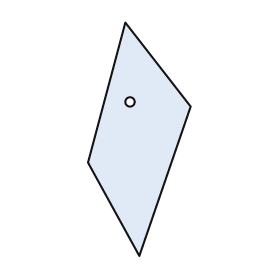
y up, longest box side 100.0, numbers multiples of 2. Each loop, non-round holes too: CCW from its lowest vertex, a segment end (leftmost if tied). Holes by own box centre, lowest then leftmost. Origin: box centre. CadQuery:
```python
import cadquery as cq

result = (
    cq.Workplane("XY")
    .moveTo(0.0, -50.0)
    .lineTo(22.0, 14.0)
    .lineTo(-6.0, 50.0)
    .lineTo(-22.0, -10.0)
    .close()
    .moveTo(-4.0, 16.0)
    .circle(2.0)
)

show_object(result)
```